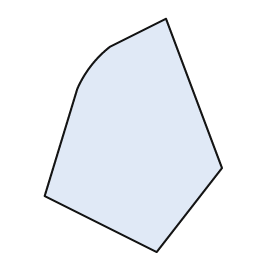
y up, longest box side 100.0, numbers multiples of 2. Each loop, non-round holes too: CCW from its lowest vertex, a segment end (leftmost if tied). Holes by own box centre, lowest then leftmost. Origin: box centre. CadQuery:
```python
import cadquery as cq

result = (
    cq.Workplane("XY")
    .moveTo(10.0, -50.0)
    .lineTo(38.0, -14.0)
    .lineTo(14.0, 50.0)
    .lineTo(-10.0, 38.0)
    .threePointArc((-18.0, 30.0), (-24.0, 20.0))
    .lineTo(-38.0, -26.0)
    .close()
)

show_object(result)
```